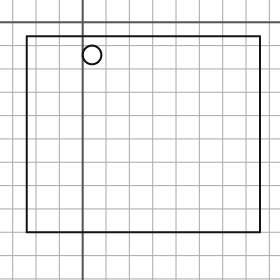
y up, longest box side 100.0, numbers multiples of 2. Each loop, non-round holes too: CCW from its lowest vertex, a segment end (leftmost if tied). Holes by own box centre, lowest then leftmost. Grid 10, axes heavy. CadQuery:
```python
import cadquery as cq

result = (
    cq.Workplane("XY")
    .moveTo(-24.0, -90.0)
    .lineTo(76.0, -90.0)
    .lineTo(76.0, -6.0)
    .lineTo(-24.0, -6.0)
    .close()
    .moveTo(4.0, -14.0)
    .circle(4.0)
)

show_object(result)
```